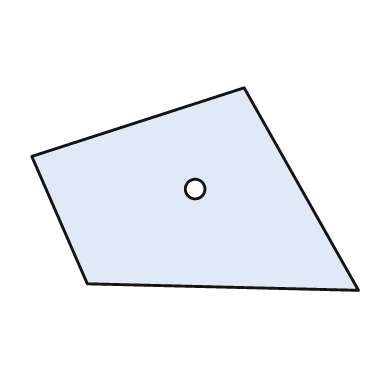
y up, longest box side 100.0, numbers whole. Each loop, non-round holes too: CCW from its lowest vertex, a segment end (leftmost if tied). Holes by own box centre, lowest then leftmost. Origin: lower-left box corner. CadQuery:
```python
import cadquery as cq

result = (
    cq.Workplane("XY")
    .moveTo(100.0, 0.0)
    .lineTo(65.0, 62.0)
    .lineTo(0.0, 41.0)
    .lineTo(17.0, 2.0)
    .close()
    .moveTo(50.0, 31.0)
    .circle(3.0)
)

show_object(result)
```